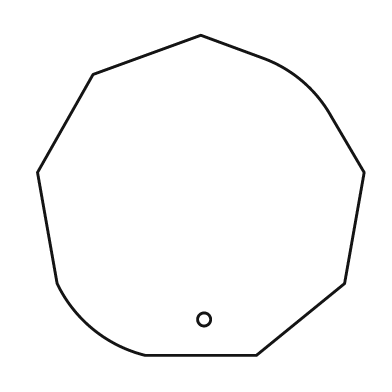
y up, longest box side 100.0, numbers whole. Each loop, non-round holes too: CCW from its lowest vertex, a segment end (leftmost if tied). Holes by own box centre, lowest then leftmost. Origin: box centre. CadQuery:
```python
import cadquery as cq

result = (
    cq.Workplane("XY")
    .moveTo(-17.0, -49.0)
    .lineTo(17.0, -49.0)
    .lineTo(44.0, -27.0)
    .lineTo(50.0, 7.0)
    .lineTo(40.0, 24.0)
    .threePointArc((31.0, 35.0), (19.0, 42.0))
    .lineTo(0.0, 49.0)
    .lineTo(-33.0, 37.0)
    .lineTo(-50.0, 7.0)
    .lineTo(-44.0, -27.0)
    .threePointArc((-33.0, -41.0), (-17.0, -49.0))
    .close()
    .moveTo(1.0, -38.0)
    .circle(2.0)
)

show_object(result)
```